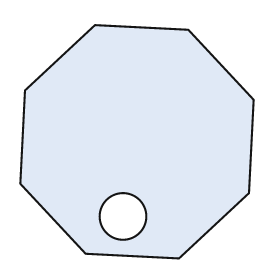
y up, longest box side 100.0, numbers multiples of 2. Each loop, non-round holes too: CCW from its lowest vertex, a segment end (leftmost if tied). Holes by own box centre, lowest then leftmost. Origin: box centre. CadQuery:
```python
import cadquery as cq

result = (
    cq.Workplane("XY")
    .moveTo(18.0, -50.0)
    .lineTo(48.0, -22.0)
    .lineTo(50.0, 18.0)
    .lineTo(22.0, 48.0)
    .lineTo(-18.0, 50.0)
    .lineTo(-48.0, 22.0)
    .lineTo(-50.0, -18.0)
    .lineTo(-22.0, -48.0)
    .close()
    .moveTo(-6.0, -32.0)
    .circle(10.0)
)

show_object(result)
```